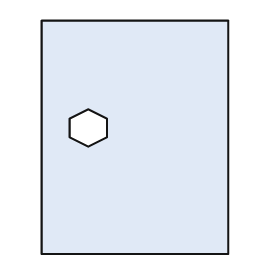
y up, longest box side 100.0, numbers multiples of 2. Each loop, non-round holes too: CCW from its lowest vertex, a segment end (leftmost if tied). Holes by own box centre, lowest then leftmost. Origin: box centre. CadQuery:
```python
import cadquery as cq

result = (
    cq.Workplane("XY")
    .moveTo(-40.0, -50.0)
    .lineTo(40.0, -50.0)
    .lineTo(40.0, 50.0)
    .lineTo(-40.0, 50.0)
    .close()
    .moveTo(-20.0, -4.0)
    .lineTo(-12.0, 0.0)
    .lineTo(-12.0, 8.0)
    .lineTo(-20.0, 12.0)
    .lineTo(-28.0, 8.0)
    .lineTo(-28.0, 0.0)
    .close()
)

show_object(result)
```